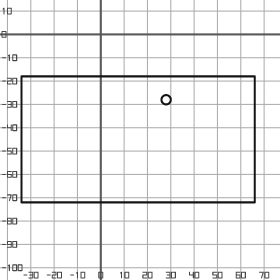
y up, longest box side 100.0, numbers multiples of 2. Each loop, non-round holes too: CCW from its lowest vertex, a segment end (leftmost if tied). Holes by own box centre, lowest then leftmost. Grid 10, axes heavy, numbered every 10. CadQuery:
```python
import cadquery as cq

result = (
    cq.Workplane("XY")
    .moveTo(-34.0, -72.0)
    .lineTo(66.0, -72.0)
    .lineTo(66.0, -18.0)
    .lineTo(-34.0, -18.0)
    .close()
    .moveTo(28.0, -28.0)
    .circle(2.0)
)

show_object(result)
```